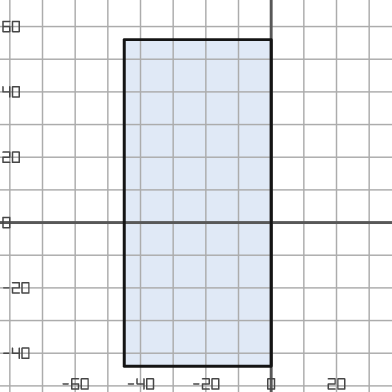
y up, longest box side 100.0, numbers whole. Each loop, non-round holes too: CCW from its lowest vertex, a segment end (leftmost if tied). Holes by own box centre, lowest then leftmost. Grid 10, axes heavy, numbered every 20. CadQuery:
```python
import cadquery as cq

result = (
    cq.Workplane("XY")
    .moveTo(-45.0, -44.0)
    .lineTo(0.0, -44.0)
    .lineTo(0.0, 56.0)
    .lineTo(-45.0, 56.0)
    .close()
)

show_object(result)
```